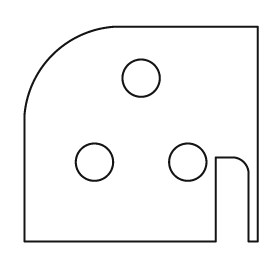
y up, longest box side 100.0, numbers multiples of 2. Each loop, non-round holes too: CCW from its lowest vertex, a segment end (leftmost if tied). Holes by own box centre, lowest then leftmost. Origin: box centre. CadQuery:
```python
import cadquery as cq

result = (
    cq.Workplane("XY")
    .moveTo(-50.0, -46.0)
    .lineTo(32.0, -46.0)
    .lineTo(32.0, -10.0)
    .lineTo(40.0, -10.0)
    .threePointArc((44.0, -12.0), (46.0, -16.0))
    .lineTo(46.0, -46.0)
    .lineTo(50.0, -46.0)
    .lineTo(50.0, 46.0)
    .lineTo(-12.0, 46.0)
    .threePointArc((-38.0, 34.0), (-50.0, 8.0))
    .close()
    .moveTo(-20.0, -12.0)
    .circle(8.0)
    .moveTo(20.0, -12.0)
    .circle(8.0)
    .moveTo(0.0, 24.0)
    .circle(8.0)
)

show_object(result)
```